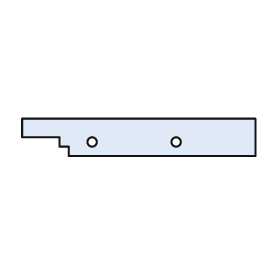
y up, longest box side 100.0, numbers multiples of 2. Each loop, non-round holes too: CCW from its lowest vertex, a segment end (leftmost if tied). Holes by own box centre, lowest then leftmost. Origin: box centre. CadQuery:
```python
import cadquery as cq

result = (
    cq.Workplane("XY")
    .moveTo(-30.0, -8.0)
    .lineTo(50.0, -8.0)
    .lineTo(50.0, 8.0)
    .lineTo(-50.0, 8.0)
    .lineTo(-50.0, 0.0)
    .lineTo(-34.0, 0.0)
    .lineTo(-34.0, -4.0)
    .lineTo(-30.0, -4.0)
    .close()
    .moveTo(-20.0, -2.0)
    .circle(2.0)
    .moveTo(16.0, -2.0)
    .circle(2.0)
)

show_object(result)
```